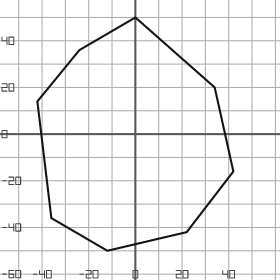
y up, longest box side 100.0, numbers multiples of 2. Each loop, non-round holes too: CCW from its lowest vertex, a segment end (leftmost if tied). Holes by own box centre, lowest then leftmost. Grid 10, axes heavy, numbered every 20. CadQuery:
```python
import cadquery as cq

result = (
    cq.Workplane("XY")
    .moveTo(-12.0, -50.0)
    .lineTo(22.0, -42.0)
    .lineTo(42.0, -16.0)
    .lineTo(34.0, 20.0)
    .lineTo(0.0, 50.0)
    .lineTo(-24.0, 36.0)
    .lineTo(-42.0, 14.0)
    .lineTo(-36.0, -36.0)
    .close()
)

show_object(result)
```